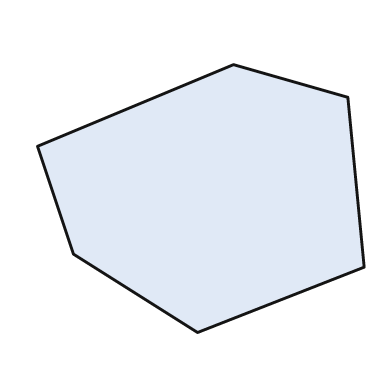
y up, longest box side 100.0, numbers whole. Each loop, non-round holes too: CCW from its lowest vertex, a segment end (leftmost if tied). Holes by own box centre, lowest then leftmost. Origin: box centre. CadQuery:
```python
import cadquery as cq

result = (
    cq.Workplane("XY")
    .moveTo(-1.0, -41.0)
    .lineTo(50.0, -21.0)
    .lineTo(45.0, 31.0)
    .lineTo(10.0, 41.0)
    .lineTo(-50.0, 16.0)
    .lineTo(-39.0, -17.0)
    .close()
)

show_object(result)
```